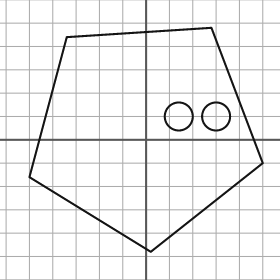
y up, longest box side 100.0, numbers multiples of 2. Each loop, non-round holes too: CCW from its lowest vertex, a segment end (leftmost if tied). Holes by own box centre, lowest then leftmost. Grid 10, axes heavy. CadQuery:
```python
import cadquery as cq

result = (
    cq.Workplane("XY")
    .moveTo(2.0, -48.0)
    .lineTo(50.0, -10.0)
    .lineTo(28.0, 48.0)
    .lineTo(-34.0, 44.0)
    .lineTo(-50.0, -16.0)
    .close()
    .moveTo(14.0, 10.0)
    .circle(6.0)
    .moveTo(30.0, 10.0)
    .circle(6.0)
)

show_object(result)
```